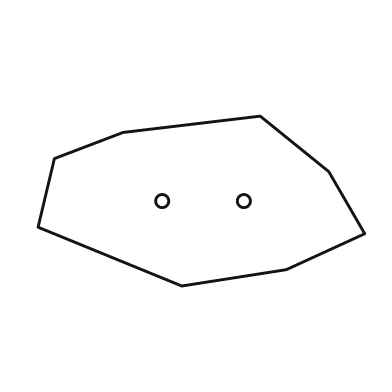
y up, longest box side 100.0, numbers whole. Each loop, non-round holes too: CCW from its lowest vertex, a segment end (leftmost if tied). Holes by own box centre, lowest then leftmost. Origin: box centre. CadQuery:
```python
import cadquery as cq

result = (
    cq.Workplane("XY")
    .moveTo(-6.0, -26.0)
    .lineTo(26.0, -21.0)
    .lineTo(50.0, -10.0)
    .lineTo(39.0, 9.0)
    .lineTo(18.0, 26.0)
    .lineTo(-24.0, 21.0)
    .lineTo(-45.0, 13.0)
    .lineTo(-50.0, -8.0)
    .close()
    .moveTo(-12.0, 0.0)
    .circle(2.0)
    .moveTo(13.0, 0.0)
    .circle(2.0)
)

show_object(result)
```